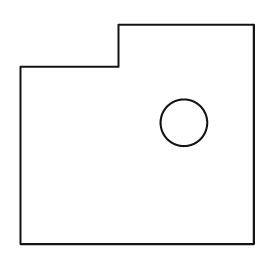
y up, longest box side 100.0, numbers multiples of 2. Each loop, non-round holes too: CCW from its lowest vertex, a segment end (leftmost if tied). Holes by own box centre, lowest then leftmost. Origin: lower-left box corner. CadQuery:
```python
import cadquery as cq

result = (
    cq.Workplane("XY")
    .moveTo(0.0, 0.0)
    .lineTo(100.0, 0.0)
    .lineTo(100.0, 94.0)
    .lineTo(42.0, 94.0)
    .lineTo(42.0, 76.0)
    .lineTo(0.0, 76.0)
    .close()
    .moveTo(70.0, 52.0)
    .circle(10.0)
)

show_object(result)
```